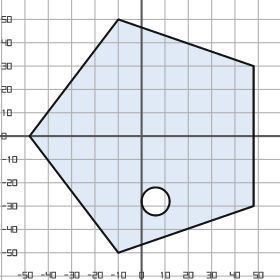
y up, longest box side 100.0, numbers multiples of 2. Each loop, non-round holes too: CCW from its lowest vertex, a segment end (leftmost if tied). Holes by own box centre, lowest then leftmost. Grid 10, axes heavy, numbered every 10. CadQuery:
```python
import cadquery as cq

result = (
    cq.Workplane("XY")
    .moveTo(-10.0, -50.0)
    .lineTo(48.0, -30.0)
    .lineTo(48.0, 30.0)
    .lineTo(-10.0, 50.0)
    .lineTo(-48.0, 0.0)
    .close()
    .moveTo(6.0, -28.0)
    .circle(6.0)
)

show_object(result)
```